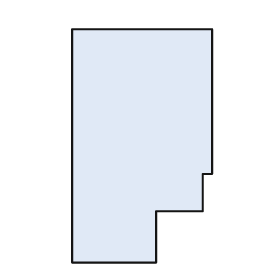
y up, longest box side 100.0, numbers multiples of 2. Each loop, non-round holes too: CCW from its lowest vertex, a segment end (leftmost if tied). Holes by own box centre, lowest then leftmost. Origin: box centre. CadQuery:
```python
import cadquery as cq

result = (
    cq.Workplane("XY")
    .moveTo(-30.0, -50.0)
    .lineTo(6.0, -50.0)
    .lineTo(6.0, -28.0)
    .lineTo(26.0, -28.0)
    .lineTo(26.0, -12.0)
    .lineTo(30.0, -12.0)
    .lineTo(30.0, 50.0)
    .lineTo(-30.0, 50.0)
    .close()
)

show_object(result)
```